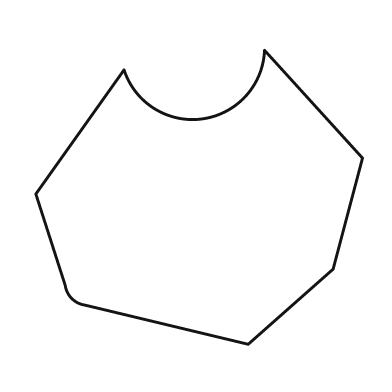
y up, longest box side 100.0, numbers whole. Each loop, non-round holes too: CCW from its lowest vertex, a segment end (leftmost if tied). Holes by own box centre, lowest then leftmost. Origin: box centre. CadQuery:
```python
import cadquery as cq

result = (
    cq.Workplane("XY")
    .moveTo(15.0, -45.0)
    .lineTo(41.0, -22.0)
    .lineTo(50.0, 12.0)
    .lineTo(20.0, 45.0)
    .threePointArc((1.0, 24.0), (-23.0, 39.0))
    .lineTo(-50.0, 1.0)
    .lineTo(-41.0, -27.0)
    .threePointArc((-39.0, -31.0), (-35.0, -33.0))
    .close()
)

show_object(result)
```